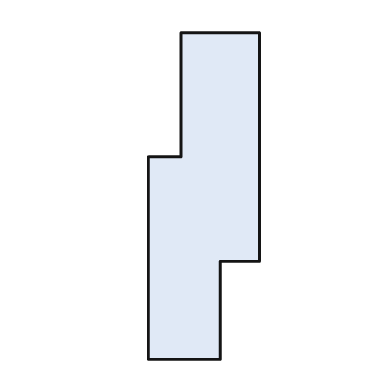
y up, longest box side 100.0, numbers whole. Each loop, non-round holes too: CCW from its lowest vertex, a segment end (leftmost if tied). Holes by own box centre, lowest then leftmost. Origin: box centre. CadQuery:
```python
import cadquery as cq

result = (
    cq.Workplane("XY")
    .moveTo(-17.0, -50.0)
    .lineTo(5.0, -50.0)
    .lineTo(5.0, -20.0)
    .lineTo(17.0, -20.0)
    .lineTo(17.0, 50.0)
    .lineTo(-7.0, 50.0)
    .lineTo(-7.0, 12.0)
    .lineTo(-17.0, 12.0)
    .close()
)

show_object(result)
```